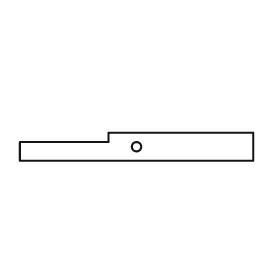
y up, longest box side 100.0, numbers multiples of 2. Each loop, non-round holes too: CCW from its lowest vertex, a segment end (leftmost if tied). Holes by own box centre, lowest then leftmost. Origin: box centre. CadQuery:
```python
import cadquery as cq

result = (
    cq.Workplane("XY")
    .moveTo(-50.0, -6.0)
    .lineTo(50.0, -6.0)
    .lineTo(50.0, 6.0)
    .lineTo(-12.0, 6.0)
    .lineTo(-12.0, 2.0)
    .lineTo(-50.0, 2.0)
    .close()
    .moveTo(0.0, 0.0)
    .circle(2.0)
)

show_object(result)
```